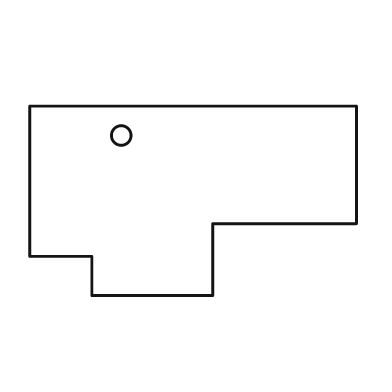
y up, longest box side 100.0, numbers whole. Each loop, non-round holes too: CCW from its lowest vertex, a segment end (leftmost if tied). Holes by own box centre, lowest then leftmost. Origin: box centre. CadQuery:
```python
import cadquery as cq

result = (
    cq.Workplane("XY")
    .moveTo(-31.0, -29.0)
    .lineTo(6.0, -29.0)
    .lineTo(6.0, -7.0)
    .lineTo(50.0, -7.0)
    .lineTo(50.0, 29.0)
    .lineTo(-50.0, 29.0)
    .lineTo(-50.0, -17.0)
    .lineTo(-31.0, -17.0)
    .close()
    .moveTo(-22.0, 20.0)
    .circle(3.0)
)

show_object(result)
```